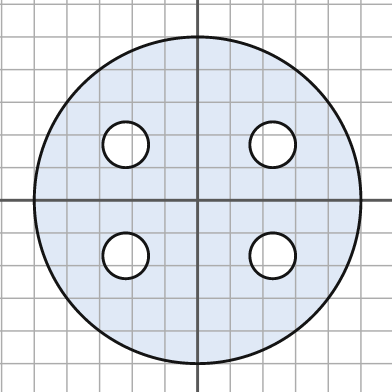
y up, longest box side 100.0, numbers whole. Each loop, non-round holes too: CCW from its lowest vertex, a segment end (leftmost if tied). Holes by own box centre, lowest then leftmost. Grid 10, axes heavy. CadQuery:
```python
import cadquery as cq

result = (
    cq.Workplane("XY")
    .moveTo(0.0, 0.0)
    .circle(50.0)
    .moveTo(-22.0, -17.0)
    .circle(7.0)
    .moveTo(23.0, -17.0)
    .circle(7.0)
    .moveTo(-22.0, 17.0)
    .circle(7.0)
    .moveTo(23.0, 17.0)
    .circle(7.0)
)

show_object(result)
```